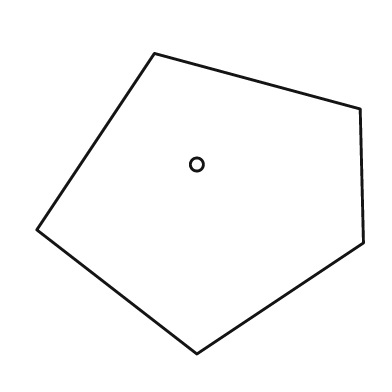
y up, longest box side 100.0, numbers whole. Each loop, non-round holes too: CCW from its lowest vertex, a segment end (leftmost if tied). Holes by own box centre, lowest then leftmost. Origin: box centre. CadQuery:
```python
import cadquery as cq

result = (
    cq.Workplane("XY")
    .moveTo(-1.0, -46.0)
    .lineTo(50.0, -12.0)
    .lineTo(49.0, 29.0)
    .lineTo(-14.0, 46.0)
    .lineTo(-50.0, -8.0)
    .close()
    .moveTo(-1.0, 12.0)
    .circle(2.0)
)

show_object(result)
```